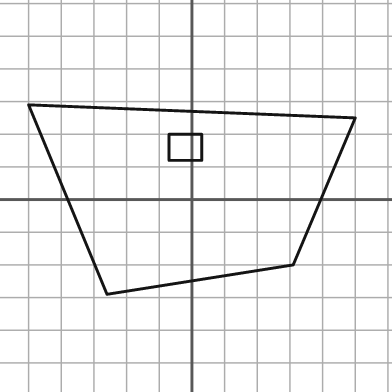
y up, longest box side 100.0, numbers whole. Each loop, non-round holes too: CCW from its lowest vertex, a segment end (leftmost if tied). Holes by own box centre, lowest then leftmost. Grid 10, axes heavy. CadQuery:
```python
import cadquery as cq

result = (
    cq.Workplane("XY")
    .moveTo(-26.0, -29.0)
    .lineTo(31.0, -20.0)
    .lineTo(50.0, 25.0)
    .lineTo(-50.0, 29.0)
    .close()
    .moveTo(-7.0, 12.0)
    .lineTo(3.0, 12.0)
    .lineTo(3.0, 20.0)
    .lineTo(-7.0, 20.0)
    .close()
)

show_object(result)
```